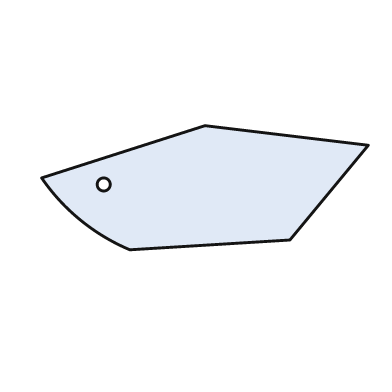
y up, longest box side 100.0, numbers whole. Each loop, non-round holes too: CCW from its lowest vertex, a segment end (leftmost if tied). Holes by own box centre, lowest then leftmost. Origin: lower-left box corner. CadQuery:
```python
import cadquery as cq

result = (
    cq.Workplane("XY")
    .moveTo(27.0, 0.0)
    .lineTo(76.0, 3.0)
    .lineTo(100.0, 32.0)
    .lineTo(50.0, 38.0)
    .lineTo(0.0, 22.0)
    .threePointArc((12.0, 9.0), (27.0, 0.0))
    .close()
    .moveTo(19.0, 20.0)
    .circle(2.0)
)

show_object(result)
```